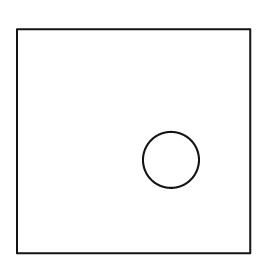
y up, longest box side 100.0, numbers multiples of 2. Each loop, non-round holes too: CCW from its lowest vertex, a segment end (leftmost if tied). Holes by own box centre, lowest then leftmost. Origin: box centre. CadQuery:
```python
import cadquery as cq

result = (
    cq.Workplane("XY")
    .moveTo(-50.0, -48.0)
    .lineTo(50.0, -48.0)
    .lineTo(50.0, 48.0)
    .lineTo(-50.0, 48.0)
    .close()
    .moveTo(16.0, -8.0)
    .circle(12.0)
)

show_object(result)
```